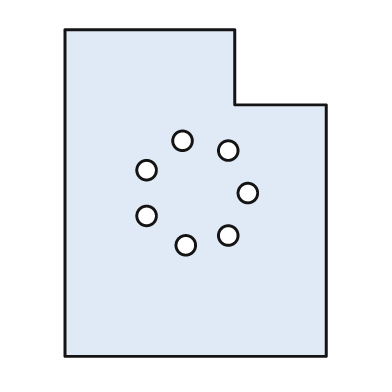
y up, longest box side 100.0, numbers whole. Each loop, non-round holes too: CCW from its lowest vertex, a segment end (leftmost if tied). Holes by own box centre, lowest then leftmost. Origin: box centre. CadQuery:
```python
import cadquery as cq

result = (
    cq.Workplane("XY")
    .moveTo(-40.0, -50.0)
    .lineTo(40.0, -50.0)
    .lineTo(40.0, 27.0)
    .lineTo(12.0, 27.0)
    .lineTo(12.0, 50.0)
    .lineTo(-40.0, 50.0)
    .close()
    .moveTo(-3.0, -16.0)
    .circle(3.0)
    .moveTo(10.0, -13.0)
    .circle(3.0)
    .moveTo(-15.0, -7.0)
    .circle(3.0)
    .moveTo(16.0, 0.0)
    .circle(3.0)
    .moveTo(-15.0, 7.0)
    .circle(3.0)
    .moveTo(10.0, 13.0)
    .circle(3.0)
    .moveTo(-4.0, 16.0)
    .circle(3.0)
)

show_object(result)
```